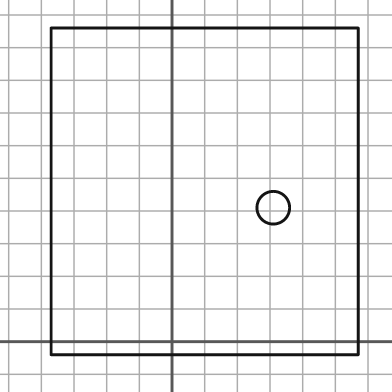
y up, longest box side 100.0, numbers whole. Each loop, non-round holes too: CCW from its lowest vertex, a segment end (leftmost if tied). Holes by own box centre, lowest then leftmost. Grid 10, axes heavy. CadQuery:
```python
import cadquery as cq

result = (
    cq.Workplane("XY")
    .moveTo(-37.0, -4.0)
    .lineTo(57.0, -4.0)
    .lineTo(57.0, 96.0)
    .lineTo(-37.0, 96.0)
    .close()
    .moveTo(31.0, 41.0)
    .circle(5.0)
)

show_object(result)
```